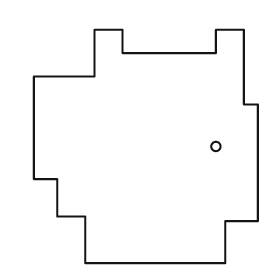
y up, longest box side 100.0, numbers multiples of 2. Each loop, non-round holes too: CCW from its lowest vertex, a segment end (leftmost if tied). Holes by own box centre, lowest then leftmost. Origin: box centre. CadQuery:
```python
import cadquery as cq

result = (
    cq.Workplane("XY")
    .moveTo(-26.0, -50.0)
    .lineTo(34.0, -50.0)
    .lineTo(34.0, -32.0)
    .lineTo(48.0, -32.0)
    .lineTo(48.0, 18.0)
    .lineTo(42.0, 18.0)
    .lineTo(42.0, 50.0)
    .lineTo(30.0, 50.0)
    .lineTo(30.0, 40.0)
    .lineTo(-10.0, 40.0)
    .lineTo(-10.0, 50.0)
    .lineTo(-22.0, 50.0)
    .lineTo(-22.0, 30.0)
    .lineTo(-48.0, 30.0)
    .lineTo(-48.0, -14.0)
    .lineTo(-38.0, -14.0)
    .lineTo(-38.0, -30.0)
    .lineTo(-26.0, -30.0)
    .close()
    .moveTo(30.0, 0.0)
    .circle(2.0)
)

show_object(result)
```